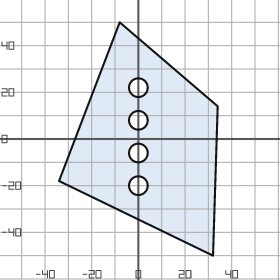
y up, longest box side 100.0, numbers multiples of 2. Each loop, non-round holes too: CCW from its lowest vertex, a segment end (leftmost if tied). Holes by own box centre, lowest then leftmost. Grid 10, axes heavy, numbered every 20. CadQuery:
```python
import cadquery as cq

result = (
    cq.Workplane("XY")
    .moveTo(32.0, -50.0)
    .lineTo(34.0, 14.0)
    .lineTo(-8.0, 50.0)
    .lineTo(-34.0, -18.0)
    .close()
    .moveTo(0.0, -20.0)
    .circle(4.0)
    .moveTo(0.0, -6.0)
    .circle(4.0)
    .moveTo(0.0, 8.0)
    .circle(4.0)
    .moveTo(0.0, 22.0)
    .circle(4.0)
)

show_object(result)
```